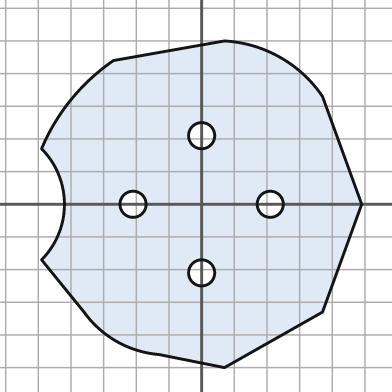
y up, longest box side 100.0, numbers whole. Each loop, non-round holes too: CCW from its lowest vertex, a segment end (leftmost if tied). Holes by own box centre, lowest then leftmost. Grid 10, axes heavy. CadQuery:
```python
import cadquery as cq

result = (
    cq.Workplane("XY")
    .moveTo(7.0, -50.0)
    .lineTo(37.0, -33.0)
    .lineTo(49.0, 0.0)
    .lineTo(37.0, 33.0)
    .threePointArc((24.0, 45.0), (7.0, 50.0))
    .lineTo(-27.0, 44.0)
    .threePointArc((-40.0, 32.0), (-49.0, 17.0))
    .threePointArc((-42.0, 0.0), (-49.0, -17.0))
    .lineTo(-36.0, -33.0)
    .threePointArc((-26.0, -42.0), (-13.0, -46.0))
    .close()
    .moveTo(0.0, -21.0)
    .circle(4.0)
    .moveTo(-21.0, 0.0)
    .circle(4.0)
    .moveTo(21.0, 0.0)
    .circle(4.0)
    .moveTo(0.0, 21.0)
    .circle(4.0)
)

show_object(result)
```